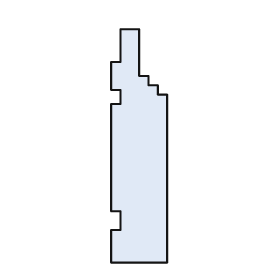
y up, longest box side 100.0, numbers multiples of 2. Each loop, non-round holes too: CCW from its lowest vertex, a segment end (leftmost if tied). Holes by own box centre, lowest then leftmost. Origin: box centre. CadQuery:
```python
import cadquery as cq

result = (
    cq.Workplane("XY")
    .moveTo(-12.0, -50.0)
    .lineTo(12.0, -50.0)
    .lineTo(12.0, 22.0)
    .lineTo(8.0, 22.0)
    .lineTo(8.0, 26.0)
    .lineTo(4.0, 26.0)
    .lineTo(4.0, 30.0)
    .lineTo(0.0, 30.0)
    .lineTo(0.0, 50.0)
    .lineTo(-8.0, 50.0)
    .lineTo(-8.0, 36.0)
    .lineTo(-12.0, 36.0)
    .lineTo(-12.0, 24.0)
    .lineTo(-8.0, 24.0)
    .lineTo(-8.0, 18.0)
    .lineTo(-12.0, 18.0)
    .lineTo(-12.0, -28.0)
    .lineTo(-8.0, -28.0)
    .lineTo(-8.0, -36.0)
    .lineTo(-12.0, -36.0)
    .close()
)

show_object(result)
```